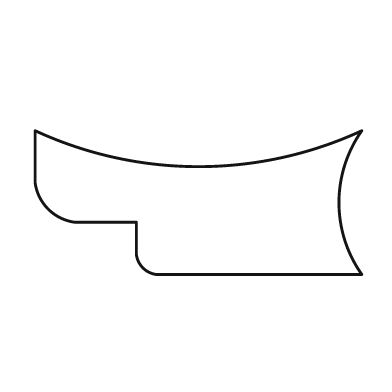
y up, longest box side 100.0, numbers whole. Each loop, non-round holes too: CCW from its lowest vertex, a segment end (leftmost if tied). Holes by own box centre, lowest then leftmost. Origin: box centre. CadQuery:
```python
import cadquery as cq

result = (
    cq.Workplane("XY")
    .moveTo(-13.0, -22.0)
    .lineTo(50.0, -22.0)
    .threePointArc((43.0, 0.0), (50.0, 22.0))
    .threePointArc((0.0, 11.0), (-50.0, 22.0))
    .lineTo(-50.0, 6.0)
    .threePointArc((-46.0, -2.0), (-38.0, -6.0))
    .lineTo(-19.0, -6.0)
    .lineTo(-19.0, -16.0)
    .threePointArc((-17.0, -20.0), (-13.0, -22.0))
    .close()
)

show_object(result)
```